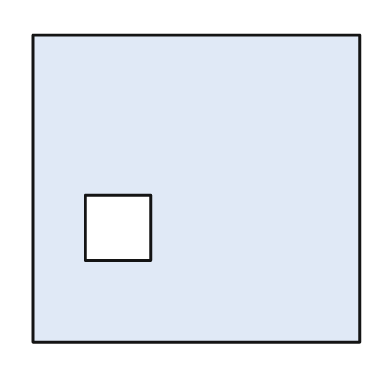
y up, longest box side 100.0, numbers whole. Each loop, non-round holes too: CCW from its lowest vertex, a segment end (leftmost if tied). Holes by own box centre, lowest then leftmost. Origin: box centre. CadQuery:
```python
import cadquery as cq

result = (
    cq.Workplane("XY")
    .moveTo(-50.0, -47.0)
    .lineTo(50.0, -47.0)
    .lineTo(50.0, 47.0)
    .lineTo(-50.0, 47.0)
    .close()
    .moveTo(-34.0, -22.0)
    .lineTo(-14.0, -22.0)
    .lineTo(-14.0, -2.0)
    .lineTo(-34.0, -2.0)
    .close()
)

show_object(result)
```